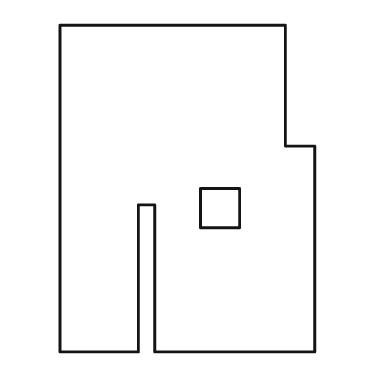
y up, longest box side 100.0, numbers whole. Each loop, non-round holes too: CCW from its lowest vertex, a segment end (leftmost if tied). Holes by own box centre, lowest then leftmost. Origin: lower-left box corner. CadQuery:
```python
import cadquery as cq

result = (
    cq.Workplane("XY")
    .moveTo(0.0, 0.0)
    .lineTo(24.0, 0.0)
    .lineTo(24.0, 45.0)
    .lineTo(29.0, 45.0)
    .lineTo(29.0, 0.0)
    .lineTo(78.0, 0.0)
    .lineTo(78.0, 63.0)
    .lineTo(69.0, 63.0)
    .lineTo(69.0, 100.0)
    .lineTo(0.0, 100.0)
    .close()
    .moveTo(43.0, 38.0)
    .lineTo(55.0, 38.0)
    .lineTo(55.0, 50.0)
    .lineTo(43.0, 50.0)
    .close()
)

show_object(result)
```